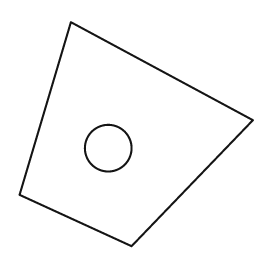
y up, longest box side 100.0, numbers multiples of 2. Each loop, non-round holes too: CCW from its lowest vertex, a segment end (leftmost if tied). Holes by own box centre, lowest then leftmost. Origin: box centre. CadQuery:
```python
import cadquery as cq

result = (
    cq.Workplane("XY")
    .moveTo(-2.0, -48.0)
    .lineTo(50.0, 6.0)
    .lineTo(-28.0, 48.0)
    .lineTo(-50.0, -26.0)
    .close()
    .moveTo(-12.0, -6.0)
    .circle(10.0)
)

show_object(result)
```